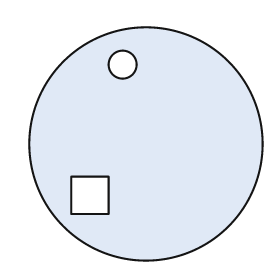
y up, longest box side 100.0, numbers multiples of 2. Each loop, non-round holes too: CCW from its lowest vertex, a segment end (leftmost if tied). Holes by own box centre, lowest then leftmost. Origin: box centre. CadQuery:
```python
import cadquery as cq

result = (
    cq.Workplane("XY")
    .moveTo(0.0, 0.0)
    .circle(50.0)
    .moveTo(-32.0, -30.0)
    .lineTo(-16.0, -30.0)
    .lineTo(-16.0, -14.0)
    .lineTo(-32.0, -14.0)
    .close()
    .moveTo(-10.0, 34.0)
    .circle(6.0)
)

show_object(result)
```